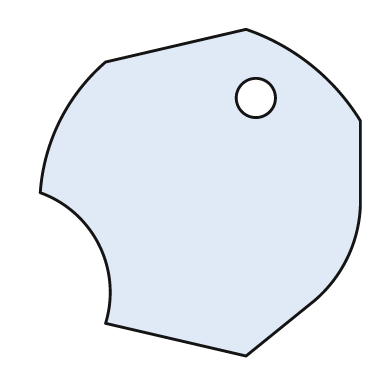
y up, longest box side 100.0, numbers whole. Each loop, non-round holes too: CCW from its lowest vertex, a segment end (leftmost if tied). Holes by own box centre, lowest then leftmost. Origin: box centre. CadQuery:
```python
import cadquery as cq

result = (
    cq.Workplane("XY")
    .moveTo(14.0, -50.0)
    .lineTo(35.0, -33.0)
    .threePointArc((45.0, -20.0), (49.0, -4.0))
    .lineTo(49.0, 22.0)
    .threePointArc((34.0, 39.0), (14.0, 50.0))
    .lineTo(-29.0, 40.0)
    .threePointArc((-43.0, 22.0), (-49.0, 0.0))
    .threePointArc((-31.0, -16.0), (-29.0, -40.0))
    .close()
    .moveTo(17.0, 29.0)
    .circle(6.0)
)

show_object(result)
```